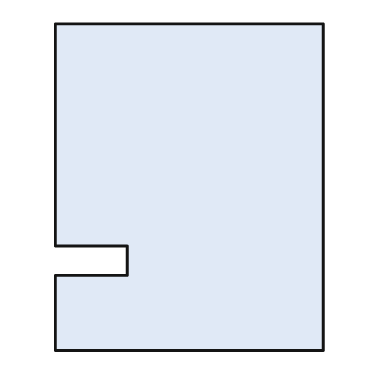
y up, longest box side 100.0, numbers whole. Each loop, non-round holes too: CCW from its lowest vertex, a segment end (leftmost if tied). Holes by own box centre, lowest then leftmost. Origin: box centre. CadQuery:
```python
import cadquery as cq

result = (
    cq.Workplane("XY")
    .moveTo(-41.0, -50.0)
    .lineTo(41.0, -50.0)
    .lineTo(41.0, 50.0)
    .lineTo(-41.0, 50.0)
    .lineTo(-41.0, -18.0)
    .lineTo(-19.0, -18.0)
    .lineTo(-19.0, -27.0)
    .lineTo(-41.0, -27.0)
    .close()
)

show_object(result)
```